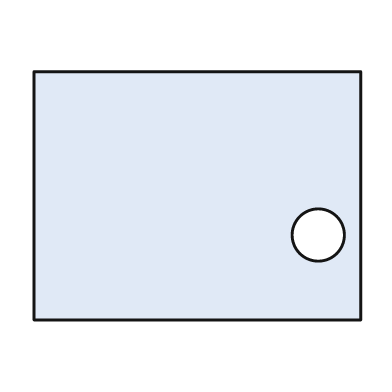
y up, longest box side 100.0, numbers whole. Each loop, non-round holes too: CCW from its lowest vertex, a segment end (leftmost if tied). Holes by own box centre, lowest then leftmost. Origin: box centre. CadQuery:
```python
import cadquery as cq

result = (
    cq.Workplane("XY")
    .moveTo(-50.0, -38.0)
    .lineTo(50.0, -38.0)
    .lineTo(50.0, 38.0)
    .lineTo(-50.0, 38.0)
    .close()
    .moveTo(37.0, -12.0)
    .circle(8.0)
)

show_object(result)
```